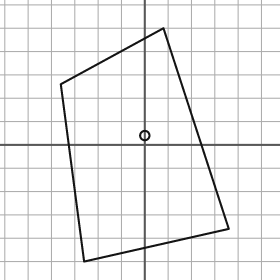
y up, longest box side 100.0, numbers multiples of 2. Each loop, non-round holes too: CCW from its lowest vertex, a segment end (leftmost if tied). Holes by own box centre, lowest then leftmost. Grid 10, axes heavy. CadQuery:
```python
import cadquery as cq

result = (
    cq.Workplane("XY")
    .moveTo(-26.0, -50.0)
    .lineTo(36.0, -36.0)
    .lineTo(8.0, 50.0)
    .lineTo(-36.0, 26.0)
    .close()
    .moveTo(0.0, 4.0)
    .circle(2.0)
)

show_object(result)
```